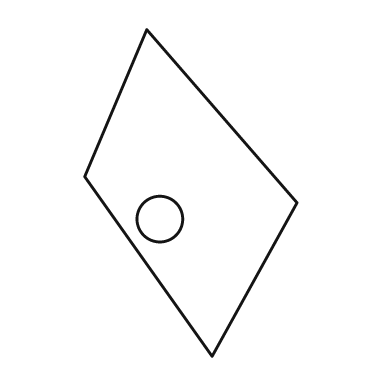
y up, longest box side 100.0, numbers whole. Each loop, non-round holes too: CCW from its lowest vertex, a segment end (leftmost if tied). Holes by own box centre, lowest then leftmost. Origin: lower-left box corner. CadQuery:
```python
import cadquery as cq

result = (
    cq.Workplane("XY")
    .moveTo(39.0, 0.0)
    .lineTo(65.0, 47.0)
    .lineTo(19.0, 100.0)
    .lineTo(0.0, 55.0)
    .close()
    .moveTo(23.0, 42.0)
    .circle(7.0)
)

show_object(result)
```